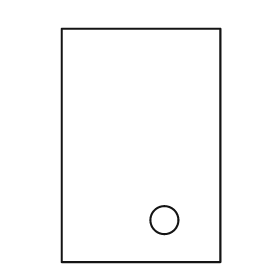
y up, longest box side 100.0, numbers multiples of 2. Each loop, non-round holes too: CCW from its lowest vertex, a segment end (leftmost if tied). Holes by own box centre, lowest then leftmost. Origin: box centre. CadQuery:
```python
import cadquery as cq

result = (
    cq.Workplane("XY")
    .moveTo(-34.0, -50.0)
    .lineTo(34.0, -50.0)
    .lineTo(34.0, 50.0)
    .lineTo(-34.0, 50.0)
    .close()
    .moveTo(10.0, -32.0)
    .circle(6.0)
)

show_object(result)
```